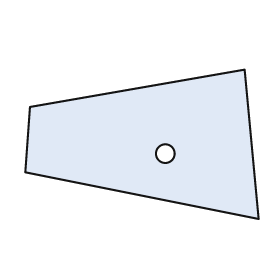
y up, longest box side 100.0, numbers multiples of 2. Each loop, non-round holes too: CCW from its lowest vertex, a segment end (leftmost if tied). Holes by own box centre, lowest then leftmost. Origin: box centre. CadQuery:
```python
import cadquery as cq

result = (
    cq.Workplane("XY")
    .moveTo(50.0, -32.0)
    .lineTo(44.0, 32.0)
    .lineTo(-48.0, 16.0)
    .lineTo(-50.0, -12.0)
    .close()
    .moveTo(10.0, -4.0)
    .circle(4.0)
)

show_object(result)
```